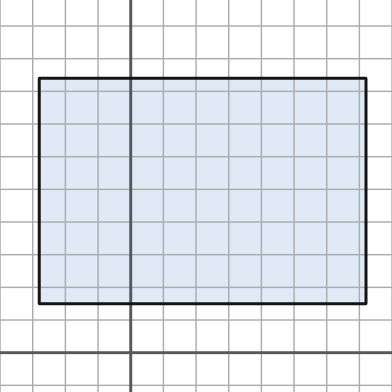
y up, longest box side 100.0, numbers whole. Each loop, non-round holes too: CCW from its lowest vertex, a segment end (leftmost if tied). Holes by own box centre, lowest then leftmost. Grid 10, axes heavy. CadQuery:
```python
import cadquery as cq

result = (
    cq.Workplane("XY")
    .moveTo(-28.0, 15.0)
    .lineTo(72.0, 15.0)
    .lineTo(72.0, 84.0)
    .lineTo(-28.0, 84.0)
    .close()
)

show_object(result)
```